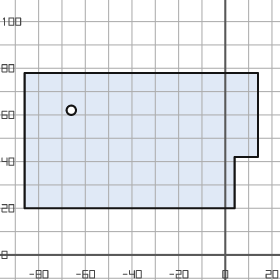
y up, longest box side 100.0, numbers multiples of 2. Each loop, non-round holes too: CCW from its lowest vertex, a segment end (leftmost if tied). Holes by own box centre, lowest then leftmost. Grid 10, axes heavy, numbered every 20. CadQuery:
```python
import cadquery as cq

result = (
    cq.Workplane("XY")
    .moveTo(-86.0, 20.0)
    .lineTo(4.0, 20.0)
    .lineTo(4.0, 42.0)
    .lineTo(14.0, 42.0)
    .lineTo(14.0, 78.0)
    .lineTo(-86.0, 78.0)
    .close()
    .moveTo(-66.0, 62.0)
    .circle(2.0)
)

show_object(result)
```